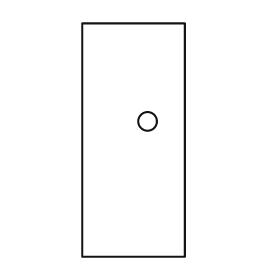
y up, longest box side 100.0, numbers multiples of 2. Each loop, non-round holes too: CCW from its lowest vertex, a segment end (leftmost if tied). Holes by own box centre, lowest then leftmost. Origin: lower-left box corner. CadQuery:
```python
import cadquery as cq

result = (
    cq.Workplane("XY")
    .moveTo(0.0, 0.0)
    .lineTo(44.0, 0.0)
    .lineTo(44.0, 100.0)
    .lineTo(0.0, 100.0)
    .close()
    .moveTo(28.0, 58.0)
    .circle(4.0)
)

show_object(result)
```